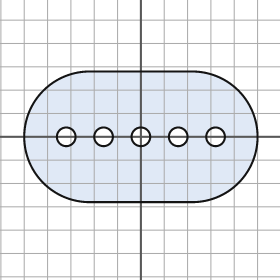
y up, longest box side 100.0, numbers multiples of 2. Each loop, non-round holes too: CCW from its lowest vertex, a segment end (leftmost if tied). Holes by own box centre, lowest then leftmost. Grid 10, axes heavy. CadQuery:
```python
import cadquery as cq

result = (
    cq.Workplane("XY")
    .moveTo(-22.0, -28.0)
    .lineTo(22.0, -28.0)
    .threePointArc((50.0, 0.0), (22.0, 28.0))
    .lineTo(-22.0, 28.0)
    .threePointArc((-50.0, 0.0), (-22.0, -28.0))
    .close()
    .moveTo(-32.0, 0.0)
    .circle(4.0)
    .moveTo(-16.0, 0.0)
    .circle(4.0)
    .moveTo(0.0, 0.0)
    .circle(4.0)
    .moveTo(16.0, 0.0)
    .circle(4.0)
    .moveTo(32.0, 0.0)
    .circle(4.0)
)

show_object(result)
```